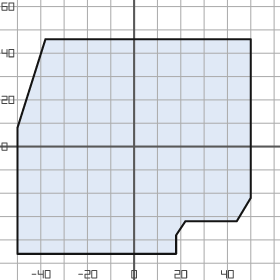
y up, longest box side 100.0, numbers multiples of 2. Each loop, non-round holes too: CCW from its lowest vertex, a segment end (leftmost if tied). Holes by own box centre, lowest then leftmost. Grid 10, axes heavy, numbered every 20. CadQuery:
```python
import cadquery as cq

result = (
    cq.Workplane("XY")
    .moveTo(-50.0, -46.0)
    .lineTo(18.0, -46.0)
    .lineTo(18.0, -38.0)
    .lineTo(22.0, -32.0)
    .lineTo(44.0, -32.0)
    .lineTo(50.0, -22.0)
    .lineTo(50.0, 46.0)
    .lineTo(-38.0, 46.0)
    .lineTo(-50.0, 8.0)
    .close()
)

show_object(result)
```